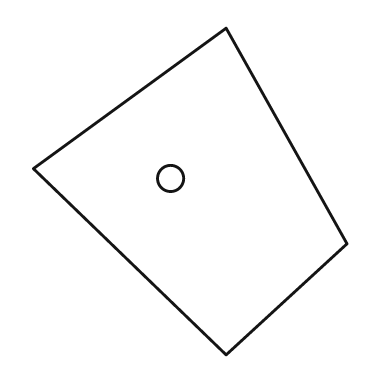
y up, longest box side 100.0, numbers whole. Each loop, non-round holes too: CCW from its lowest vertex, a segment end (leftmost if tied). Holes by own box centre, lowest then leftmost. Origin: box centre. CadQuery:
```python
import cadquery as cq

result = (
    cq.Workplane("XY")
    .moveTo(11.0, -50.0)
    .lineTo(48.0, -16.0)
    .lineTo(11.0, 50.0)
    .lineTo(-48.0, 7.0)
    .close()
    .moveTo(-6.0, 4.0)
    .circle(4.0)
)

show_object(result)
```